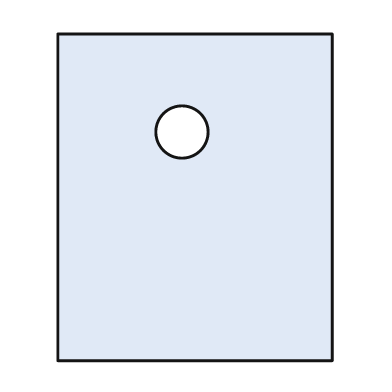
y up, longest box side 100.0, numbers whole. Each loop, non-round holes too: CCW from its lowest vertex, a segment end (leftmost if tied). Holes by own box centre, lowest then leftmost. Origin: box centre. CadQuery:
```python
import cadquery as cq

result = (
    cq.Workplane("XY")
    .moveTo(-42.0, -50.0)
    .lineTo(42.0, -50.0)
    .lineTo(42.0, 50.0)
    .lineTo(-42.0, 50.0)
    .close()
    .moveTo(-4.0, 20.0)
    .circle(8.0)
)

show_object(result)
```